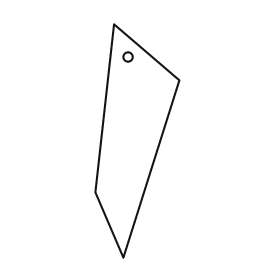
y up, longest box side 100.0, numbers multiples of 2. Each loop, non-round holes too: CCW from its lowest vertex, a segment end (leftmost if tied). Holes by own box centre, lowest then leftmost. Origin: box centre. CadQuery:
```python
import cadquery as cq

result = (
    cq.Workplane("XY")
    .moveTo(-6.0, -50.0)
    .lineTo(18.0, 26.0)
    .lineTo(-10.0, 50.0)
    .lineTo(-18.0, -22.0)
    .close()
    .moveTo(-4.0, 36.0)
    .circle(2.0)
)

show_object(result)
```